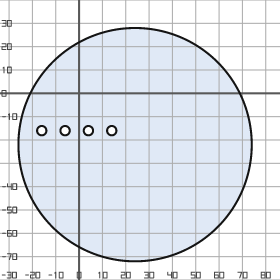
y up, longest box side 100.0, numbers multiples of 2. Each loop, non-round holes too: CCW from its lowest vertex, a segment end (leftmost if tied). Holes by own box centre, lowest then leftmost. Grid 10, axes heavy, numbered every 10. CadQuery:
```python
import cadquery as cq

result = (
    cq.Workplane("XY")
    .moveTo(24.0, -22.0)
    .circle(50.0)
    .moveTo(-16.0, -16.0)
    .circle(2.0)
    .moveTo(-6.0, -16.0)
    .circle(2.0)
    .moveTo(4.0, -16.0)
    .circle(2.0)
    .moveTo(14.0, -16.0)
    .circle(2.0)
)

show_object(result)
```